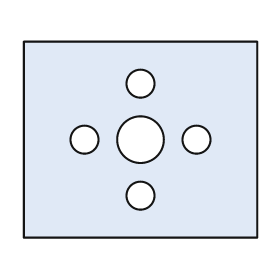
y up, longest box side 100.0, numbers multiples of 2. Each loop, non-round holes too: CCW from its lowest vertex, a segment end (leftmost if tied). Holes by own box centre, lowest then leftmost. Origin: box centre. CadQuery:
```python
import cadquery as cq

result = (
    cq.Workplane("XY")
    .moveTo(-50.0, -42.0)
    .lineTo(50.0, -42.0)
    .lineTo(50.0, 42.0)
    .lineTo(-50.0, 42.0)
    .close()
    .moveTo(0.0, -24.0)
    .circle(6.0)
    .moveTo(-24.0, 0.0)
    .circle(6.0)
    .moveTo(0.0, 0.0)
    .circle(10.0)
    .moveTo(24.0, 0.0)
    .circle(6.0)
    .moveTo(0.0, 24.0)
    .circle(6.0)
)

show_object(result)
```